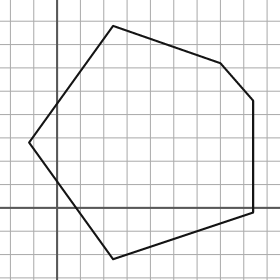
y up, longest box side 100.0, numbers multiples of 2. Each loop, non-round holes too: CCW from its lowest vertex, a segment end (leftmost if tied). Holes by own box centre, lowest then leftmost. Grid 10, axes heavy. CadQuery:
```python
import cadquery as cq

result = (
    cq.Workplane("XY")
    .moveTo(24.0, -22.0)
    .lineTo(84.0, -2.0)
    .lineTo(84.0, 46.0)
    .lineTo(70.0, 62.0)
    .lineTo(24.0, 78.0)
    .lineTo(-12.0, 28.0)
    .close()
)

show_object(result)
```